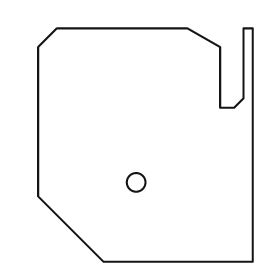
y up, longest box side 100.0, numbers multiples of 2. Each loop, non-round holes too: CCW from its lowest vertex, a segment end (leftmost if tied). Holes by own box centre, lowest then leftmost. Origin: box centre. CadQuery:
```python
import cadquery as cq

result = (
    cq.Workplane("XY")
    .moveTo(-18.0, -50.0)
    .lineTo(46.0, -50.0)
    .lineTo(46.0, 50.0)
    .lineTo(42.0, 50.0)
    .lineTo(42.0, 20.0)
    .lineTo(38.0, 16.0)
    .lineTo(32.0, 16.0)
    .lineTo(32.0, 42.0)
    .lineTo(18.0, 50.0)
    .lineTo(-38.0, 50.0)
    .lineTo(-46.0, 42.0)
    .lineTo(-46.0, -22.0)
    .close()
    .moveTo(-4.0, -16.0)
    .circle(4.0)
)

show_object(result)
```